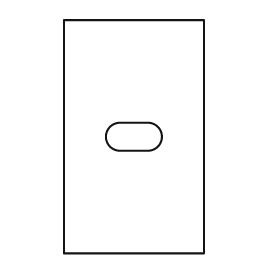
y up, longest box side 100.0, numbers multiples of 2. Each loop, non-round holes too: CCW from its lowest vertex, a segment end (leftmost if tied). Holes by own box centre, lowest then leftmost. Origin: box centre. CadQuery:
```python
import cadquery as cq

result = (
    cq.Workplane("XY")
    .moveTo(-30.0, -50.0)
    .lineTo(30.0, -50.0)
    .lineTo(30.0, 50.0)
    .lineTo(-30.0, 50.0)
    .close()
    .moveTo(-6.0, -6.0)
    .lineTo(6.0, -6.0)
    .threePointArc((12.0, 0.0), (6.0, 6.0))
    .lineTo(-6.0, 6.0)
    .threePointArc((-12.0, 0.0), (-6.0, -6.0))
    .close()
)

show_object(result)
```